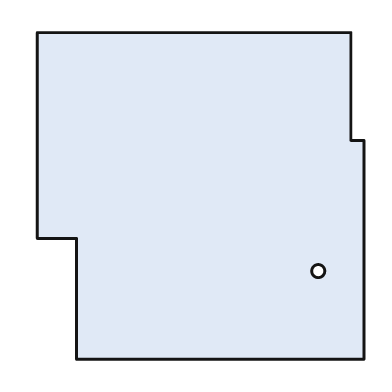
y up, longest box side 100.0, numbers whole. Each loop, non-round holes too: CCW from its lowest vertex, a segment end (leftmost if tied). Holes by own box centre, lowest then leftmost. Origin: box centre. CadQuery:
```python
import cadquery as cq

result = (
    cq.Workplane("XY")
    .moveTo(-38.0, -50.0)
    .lineTo(50.0, -50.0)
    .lineTo(50.0, 17.0)
    .lineTo(46.0, 17.0)
    .lineTo(46.0, 50.0)
    .lineTo(-50.0, 50.0)
    .lineTo(-50.0, -13.0)
    .lineTo(-38.0, -13.0)
    .close()
    .moveTo(36.0, -23.0)
    .circle(2.0)
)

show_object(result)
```